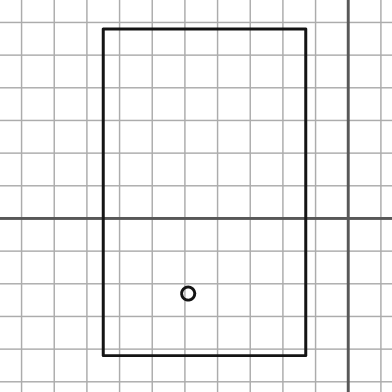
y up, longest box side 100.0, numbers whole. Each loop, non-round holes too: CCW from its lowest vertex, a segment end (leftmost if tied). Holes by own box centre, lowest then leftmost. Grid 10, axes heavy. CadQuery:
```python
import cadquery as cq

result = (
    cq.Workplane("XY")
    .moveTo(-75.0, -42.0)
    .lineTo(-13.0, -42.0)
    .lineTo(-13.0, 58.0)
    .lineTo(-75.0, 58.0)
    .close()
    .moveTo(-49.0, -23.0)
    .circle(2.0)
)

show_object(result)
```